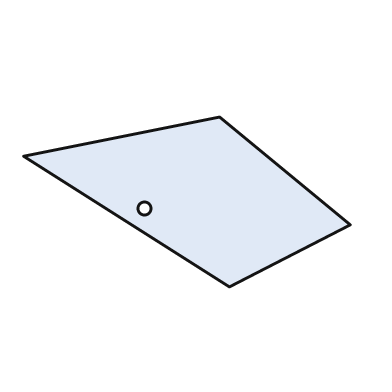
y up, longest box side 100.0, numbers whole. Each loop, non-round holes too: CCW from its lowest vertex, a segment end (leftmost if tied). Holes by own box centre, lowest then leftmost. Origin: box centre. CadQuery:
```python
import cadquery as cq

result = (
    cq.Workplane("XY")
    .moveTo(13.0, -26.0)
    .lineTo(50.0, -7.0)
    .lineTo(10.0, 26.0)
    .lineTo(-50.0, 14.0)
    .close()
    .moveTo(-13.0, -2.0)
    .circle(2.0)
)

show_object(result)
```